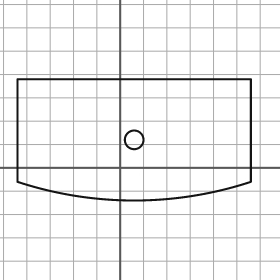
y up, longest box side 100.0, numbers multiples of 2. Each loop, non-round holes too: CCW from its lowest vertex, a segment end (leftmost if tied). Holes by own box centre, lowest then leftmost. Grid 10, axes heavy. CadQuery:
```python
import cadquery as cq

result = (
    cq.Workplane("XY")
    .moveTo(-44.0, -6.0)
    .threePointArc((6.0, -14.0), (56.0, -6.0))
    .lineTo(56.0, 38.0)
    .lineTo(-44.0, 38.0)
    .close()
    .moveTo(6.0, 12.0)
    .circle(4.0)
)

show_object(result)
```